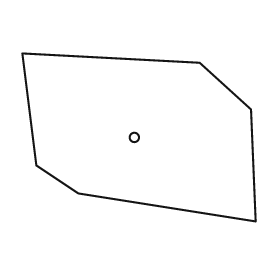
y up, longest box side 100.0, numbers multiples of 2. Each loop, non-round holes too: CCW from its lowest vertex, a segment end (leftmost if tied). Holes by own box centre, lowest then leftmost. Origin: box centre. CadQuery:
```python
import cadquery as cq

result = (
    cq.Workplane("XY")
    .moveTo(50.0, -36.0)
    .lineTo(48.0, 12.0)
    .lineTo(26.0, 32.0)
    .lineTo(-50.0, 36.0)
    .lineTo(-44.0, -12.0)
    .lineTo(-26.0, -24.0)
    .close()
    .moveTo(-2.0, 0.0)
    .circle(2.0)
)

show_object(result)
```